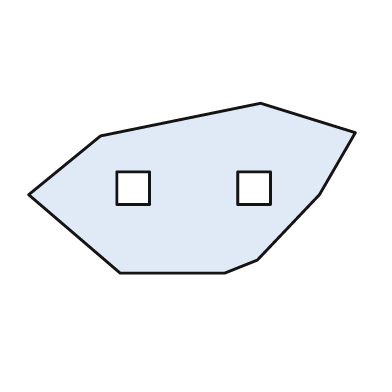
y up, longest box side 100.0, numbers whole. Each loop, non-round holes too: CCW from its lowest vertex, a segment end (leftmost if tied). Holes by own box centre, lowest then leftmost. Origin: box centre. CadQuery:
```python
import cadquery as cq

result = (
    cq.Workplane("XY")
    .moveTo(-22.0, -26.0)
    .lineTo(10.0, -26.0)
    .lineTo(20.0, -22.0)
    .lineTo(39.0, -2.0)
    .lineTo(50.0, 17.0)
    .lineTo(21.0, 26.0)
    .lineTo(-28.0, 16.0)
    .lineTo(-50.0, -2.0)
    .close()
    .moveTo(-23.0, -5.0)
    .lineTo(-13.0, -5.0)
    .lineTo(-13.0, 5.0)
    .lineTo(-23.0, 5.0)
    .close()
    .moveTo(14.0, -5.0)
    .lineTo(24.0, -5.0)
    .lineTo(24.0, 5.0)
    .lineTo(14.0, 5.0)
    .close()
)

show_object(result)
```